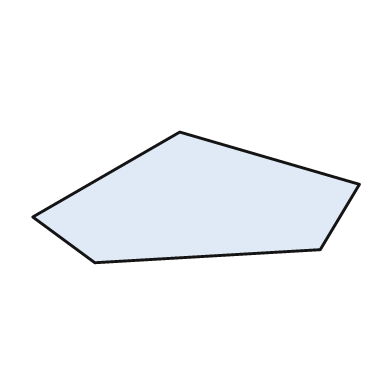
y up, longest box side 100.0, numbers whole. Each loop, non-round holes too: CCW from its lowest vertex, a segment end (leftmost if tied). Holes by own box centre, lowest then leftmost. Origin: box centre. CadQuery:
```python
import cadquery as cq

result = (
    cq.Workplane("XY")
    .moveTo(-31.0, -20.0)
    .lineTo(38.0, -16.0)
    .lineTo(50.0, 4.0)
    .lineTo(-5.0, 20.0)
    .lineTo(-50.0, -6.0)
    .close()
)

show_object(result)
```